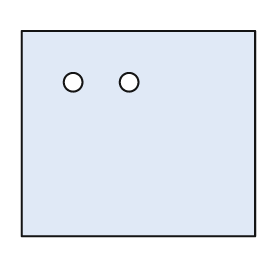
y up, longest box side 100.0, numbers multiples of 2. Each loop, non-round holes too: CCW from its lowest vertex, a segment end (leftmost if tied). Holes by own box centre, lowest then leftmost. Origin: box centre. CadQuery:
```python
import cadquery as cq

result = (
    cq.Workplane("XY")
    .moveTo(-50.0, -44.0)
    .lineTo(50.0, -44.0)
    .lineTo(50.0, 44.0)
    .lineTo(-50.0, 44.0)
    .close()
    .moveTo(-28.0, 22.0)
    .circle(4.0)
    .moveTo(-4.0, 22.0)
    .circle(4.0)
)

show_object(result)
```